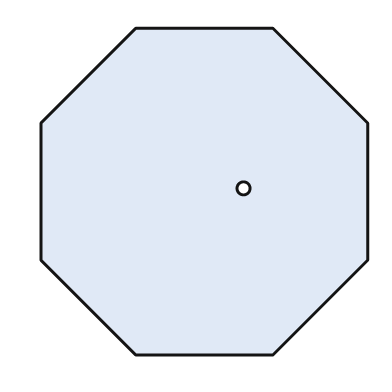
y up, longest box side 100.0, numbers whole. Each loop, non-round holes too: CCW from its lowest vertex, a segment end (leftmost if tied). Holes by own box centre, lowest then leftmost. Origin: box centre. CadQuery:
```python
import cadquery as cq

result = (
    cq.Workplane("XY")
    .moveTo(-21.0, -50.0)
    .lineTo(21.0, -50.0)
    .lineTo(50.0, -21.0)
    .lineTo(50.0, 21.0)
    .lineTo(21.0, 50.0)
    .lineTo(-21.0, 50.0)
    .lineTo(-50.0, 21.0)
    .lineTo(-50.0, -21.0)
    .close()
    .moveTo(12.0, 1.0)
    .circle(2.0)
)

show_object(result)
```